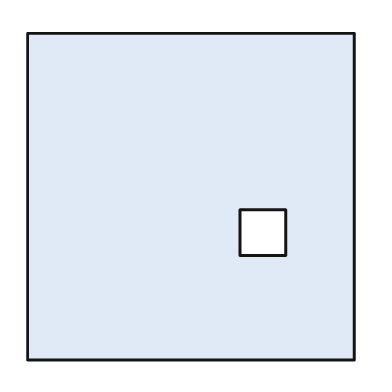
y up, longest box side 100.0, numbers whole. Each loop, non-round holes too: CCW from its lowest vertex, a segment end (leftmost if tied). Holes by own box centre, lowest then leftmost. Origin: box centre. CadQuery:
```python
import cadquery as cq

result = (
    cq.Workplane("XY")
    .moveTo(-50.0, -50.0)
    .lineTo(50.0, -50.0)
    .lineTo(50.0, 50.0)
    .lineTo(-50.0, 50.0)
    .close()
    .moveTo(15.0, -18.0)
    .lineTo(29.0, -18.0)
    .lineTo(29.0, -4.0)
    .lineTo(15.0, -4.0)
    .close()
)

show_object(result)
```